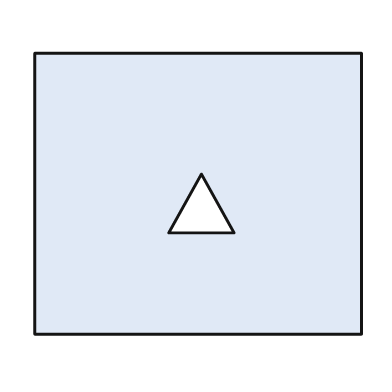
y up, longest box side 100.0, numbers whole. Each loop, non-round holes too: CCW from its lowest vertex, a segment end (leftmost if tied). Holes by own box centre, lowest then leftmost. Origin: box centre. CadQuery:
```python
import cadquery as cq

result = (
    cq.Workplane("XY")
    .moveTo(-50.0, -43.0)
    .lineTo(50.0, -43.0)
    .lineTo(50.0, 43.0)
    .lineTo(-50.0, 43.0)
    .close()
    .moveTo(-9.0, -12.0)
    .lineTo(11.0, -12.0)
    .lineTo(1.0, 6.0)
    .close()
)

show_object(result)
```